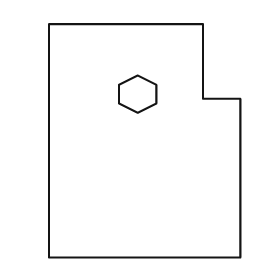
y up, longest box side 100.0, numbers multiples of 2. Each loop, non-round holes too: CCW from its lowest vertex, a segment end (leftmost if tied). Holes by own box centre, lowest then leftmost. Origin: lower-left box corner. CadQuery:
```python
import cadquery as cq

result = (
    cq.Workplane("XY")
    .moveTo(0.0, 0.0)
    .lineTo(82.0, 0.0)
    .lineTo(82.0, 68.0)
    .lineTo(66.0, 68.0)
    .lineTo(66.0, 100.0)
    .lineTo(0.0, 100.0)
    .close()
    .moveTo(38.0, 62.0)
    .lineTo(46.0, 66.0)
    .lineTo(46.0, 74.0)
    .lineTo(38.0, 78.0)
    .lineTo(30.0, 74.0)
    .lineTo(30.0, 66.0)
    .close()
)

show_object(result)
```